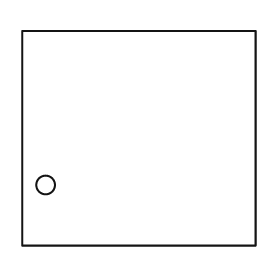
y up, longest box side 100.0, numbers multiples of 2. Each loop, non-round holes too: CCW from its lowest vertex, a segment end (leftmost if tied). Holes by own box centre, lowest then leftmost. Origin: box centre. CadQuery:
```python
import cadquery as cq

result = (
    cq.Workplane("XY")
    .moveTo(-50.0, -46.0)
    .lineTo(50.0, -46.0)
    .lineTo(50.0, 46.0)
    .lineTo(-50.0, 46.0)
    .close()
    .moveTo(-40.0, -20.0)
    .circle(4.0)
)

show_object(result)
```